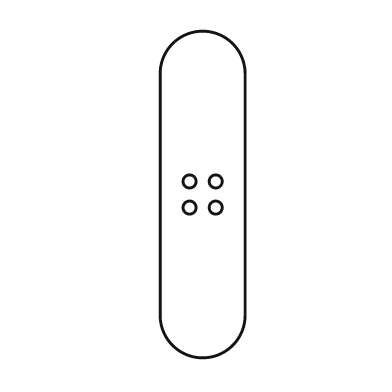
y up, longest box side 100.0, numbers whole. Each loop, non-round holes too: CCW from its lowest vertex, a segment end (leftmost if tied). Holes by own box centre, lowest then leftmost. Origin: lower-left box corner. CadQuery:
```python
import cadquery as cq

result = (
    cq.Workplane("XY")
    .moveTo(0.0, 13.0)
    .threePointArc((13.0, 0.0), (26.0, 13.0))
    .lineTo(26.0, 87.0)
    .threePointArc((13.0, 100.0), (0.0, 87.0))
    .close()
    .moveTo(9.0, 46.0)
    .circle(2.0)
    .moveTo(17.0, 46.0)
    .circle(2.0)
    .moveTo(9.0, 54.0)
    .circle(2.0)
    .moveTo(17.0, 54.0)
    .circle(2.0)
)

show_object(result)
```